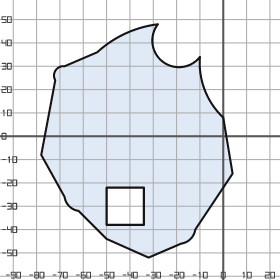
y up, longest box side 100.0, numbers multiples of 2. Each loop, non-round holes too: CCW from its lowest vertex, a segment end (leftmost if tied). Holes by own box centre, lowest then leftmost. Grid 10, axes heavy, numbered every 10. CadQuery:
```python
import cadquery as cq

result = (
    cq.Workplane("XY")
    .moveTo(-32.0, -52.0)
    .lineTo(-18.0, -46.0)
    .threePointArc((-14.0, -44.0), (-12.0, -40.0))
    .lineTo(4.0, -16.0)
    .lineTo(0.0, 8.0)
    .threePointArc((-8.0, 20.0), (-10.0, 34.0))
    .threePointArc((-26.0, 32.0), (-28.0, 48.0))
    .threePointArc((-42.0, 44.0), (-54.0, 36.0))
    .lineTo(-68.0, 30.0)
    .threePointArc((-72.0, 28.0), (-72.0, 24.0))
    .lineTo(-78.0, -8.0)
    .lineTo(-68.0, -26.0)
    .threePointArc((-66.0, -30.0), (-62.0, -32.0))
    .lineTo(-50.0, -44.0)
    .close()
    .moveTo(-50.0, -38.0)
    .lineTo(-34.0, -38.0)
    .lineTo(-34.0, -22.0)
    .lineTo(-50.0, -22.0)
    .close()
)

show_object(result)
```